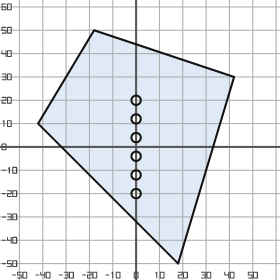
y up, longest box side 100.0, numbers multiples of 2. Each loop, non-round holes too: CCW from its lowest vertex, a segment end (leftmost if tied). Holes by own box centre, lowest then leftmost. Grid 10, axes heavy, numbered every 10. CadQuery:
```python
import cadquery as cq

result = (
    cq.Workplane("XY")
    .moveTo(18.0, -50.0)
    .lineTo(42.0, 30.0)
    .lineTo(-18.0, 50.0)
    .lineTo(-42.0, 10.0)
    .close()
    .moveTo(0.0, -20.0)
    .circle(2.0)
    .moveTo(0.0, -12.0)
    .circle(2.0)
    .moveTo(0.0, -4.0)
    .circle(2.0)
    .moveTo(0.0, 4.0)
    .circle(2.0)
    .moveTo(0.0, 12.0)
    .circle(2.0)
    .moveTo(0.0, 20.0)
    .circle(2.0)
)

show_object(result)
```